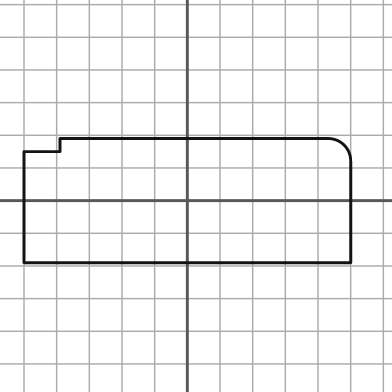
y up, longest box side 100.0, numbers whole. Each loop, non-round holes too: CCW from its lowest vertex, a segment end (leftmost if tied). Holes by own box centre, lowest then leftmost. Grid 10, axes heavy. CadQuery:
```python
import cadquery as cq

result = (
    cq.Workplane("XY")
    .moveTo(-50.0, -19.0)
    .lineTo(50.0, -19.0)
    .lineTo(50.0, 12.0)
    .threePointArc((48.0, 17.0), (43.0, 19.0))
    .lineTo(-39.0, 19.0)
    .lineTo(-39.0, 15.0)
    .lineTo(-50.0, 15.0)
    .close()
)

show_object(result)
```